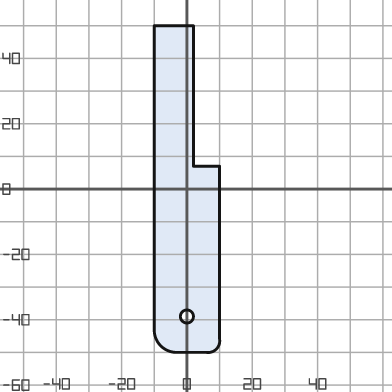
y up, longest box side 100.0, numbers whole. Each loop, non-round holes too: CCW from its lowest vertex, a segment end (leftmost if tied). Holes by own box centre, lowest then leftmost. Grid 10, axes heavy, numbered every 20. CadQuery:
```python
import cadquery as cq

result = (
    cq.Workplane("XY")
    .moveTo(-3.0, -50.0)
    .lineTo(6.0, -50.0)
    .threePointArc((9.0, -49.0), (10.0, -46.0))
    .lineTo(10.0, 7.0)
    .lineTo(2.0, 7.0)
    .lineTo(2.0, 50.0)
    .lineTo(-10.0, 50.0)
    .lineTo(-10.0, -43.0)
    .threePointArc((-8.0, -48.0), (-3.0, -50.0))
    .close()
    .moveTo(0.0, -39.0)
    .circle(2.0)
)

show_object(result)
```